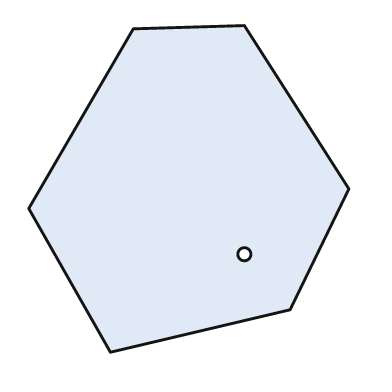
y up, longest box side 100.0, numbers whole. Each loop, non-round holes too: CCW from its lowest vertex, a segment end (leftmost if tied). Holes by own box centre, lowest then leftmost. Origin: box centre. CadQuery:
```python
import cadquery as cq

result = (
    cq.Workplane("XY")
    .moveTo(-24.0, -50.0)
    .lineTo(31.0, -37.0)
    .lineTo(49.0, 0.0)
    .lineTo(17.0, 50.0)
    .lineTo(-17.0, 49.0)
    .lineTo(-49.0, -6.0)
    .close()
    .moveTo(17.0, -20.0)
    .circle(2.0)
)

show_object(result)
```